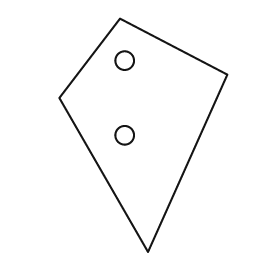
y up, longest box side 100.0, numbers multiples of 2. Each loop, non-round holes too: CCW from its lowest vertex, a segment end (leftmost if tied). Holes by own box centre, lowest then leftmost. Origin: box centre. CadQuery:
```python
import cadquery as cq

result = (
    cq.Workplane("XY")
    .moveTo(2.0, -50.0)
    .lineTo(36.0, 26.0)
    .lineTo(-10.0, 50.0)
    .lineTo(-36.0, 16.0)
    .close()
    .moveTo(-8.0, 0.0)
    .circle(4.0)
    .moveTo(-8.0, 32.0)
    .circle(4.0)
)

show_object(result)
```